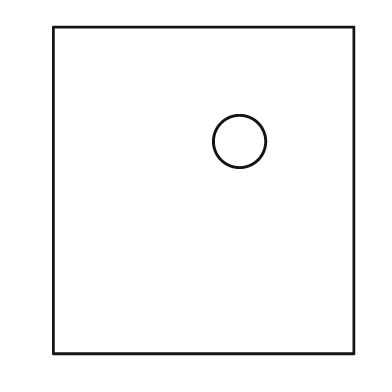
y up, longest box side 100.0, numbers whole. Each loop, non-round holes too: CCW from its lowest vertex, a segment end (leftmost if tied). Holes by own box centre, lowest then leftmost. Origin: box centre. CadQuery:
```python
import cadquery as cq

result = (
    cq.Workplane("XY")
    .moveTo(-46.0, -50.0)
    .lineTo(46.0, -50.0)
    .lineTo(46.0, 50.0)
    .lineTo(-46.0, 50.0)
    .close()
    .moveTo(11.0, 15.0)
    .circle(8.0)
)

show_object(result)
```